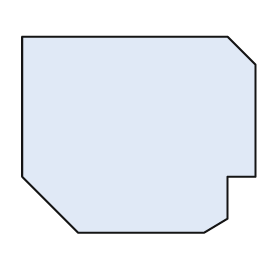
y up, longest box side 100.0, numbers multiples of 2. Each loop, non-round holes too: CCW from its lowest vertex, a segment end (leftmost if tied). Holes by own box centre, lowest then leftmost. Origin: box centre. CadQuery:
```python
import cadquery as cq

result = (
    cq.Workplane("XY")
    .moveTo(-26.0, -42.0)
    .lineTo(28.0, -42.0)
    .lineTo(38.0, -36.0)
    .lineTo(38.0, -18.0)
    .lineTo(50.0, -18.0)
    .lineTo(50.0, 30.0)
    .lineTo(38.0, 42.0)
    .lineTo(-50.0, 42.0)
    .lineTo(-50.0, -18.0)
    .close()
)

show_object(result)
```